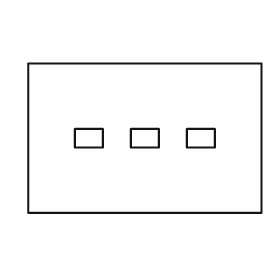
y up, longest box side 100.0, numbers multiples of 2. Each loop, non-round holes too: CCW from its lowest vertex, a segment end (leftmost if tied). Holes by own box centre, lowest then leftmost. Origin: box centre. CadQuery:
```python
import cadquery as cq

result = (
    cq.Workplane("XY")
    .moveTo(-50.0, -32.0)
    .lineTo(50.0, -32.0)
    .lineTo(50.0, 32.0)
    .lineTo(-50.0, 32.0)
    .close()
    .moveTo(-30.0, -4.0)
    .lineTo(-18.0, -4.0)
    .lineTo(-18.0, 4.0)
    .lineTo(-30.0, 4.0)
    .close()
    .moveTo(-6.0, -4.0)
    .lineTo(6.0, -4.0)
    .lineTo(6.0, 4.0)
    .lineTo(-6.0, 4.0)
    .close()
    .moveTo(18.0, -4.0)
    .lineTo(30.0, -4.0)
    .lineTo(30.0, 4.0)
    .lineTo(18.0, 4.0)
    .close()
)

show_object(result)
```